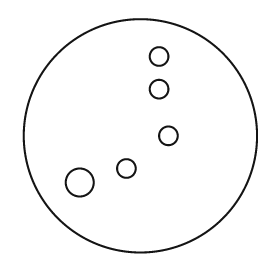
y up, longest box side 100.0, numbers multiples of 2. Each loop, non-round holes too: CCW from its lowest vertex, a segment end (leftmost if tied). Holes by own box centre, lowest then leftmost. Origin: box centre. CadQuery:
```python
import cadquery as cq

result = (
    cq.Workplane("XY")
    .moveTo(0.0, 0.0)
    .circle(50.0)
    .moveTo(-26.0, -20.0)
    .circle(6.0)
    .moveTo(-6.0, -14.0)
    .circle(4.0)
    .moveTo(12.0, 0.0)
    .circle(4.0)
    .moveTo(8.0, 20.0)
    .circle(4.0)
    .moveTo(8.0, 34.0)
    .circle(4.0)
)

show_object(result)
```